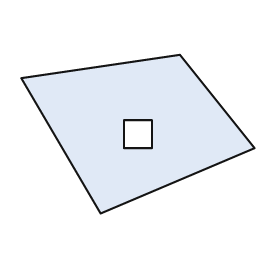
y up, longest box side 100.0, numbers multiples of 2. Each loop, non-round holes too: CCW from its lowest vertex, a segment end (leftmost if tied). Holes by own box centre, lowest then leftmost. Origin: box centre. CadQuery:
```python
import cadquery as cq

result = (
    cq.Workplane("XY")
    .moveTo(-16.0, -34.0)
    .lineTo(50.0, -6.0)
    .lineTo(18.0, 34.0)
    .lineTo(-50.0, 24.0)
    .close()
    .moveTo(-6.0, -6.0)
    .lineTo(6.0, -6.0)
    .lineTo(6.0, 6.0)
    .lineTo(-6.0, 6.0)
    .close()
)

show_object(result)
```